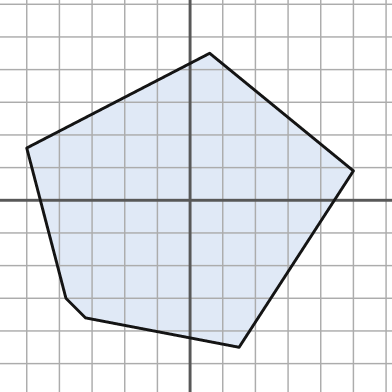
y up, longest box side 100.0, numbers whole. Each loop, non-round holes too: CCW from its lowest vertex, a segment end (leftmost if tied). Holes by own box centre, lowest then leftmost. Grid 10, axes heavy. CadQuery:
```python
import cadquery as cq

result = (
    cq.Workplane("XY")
    .moveTo(15.0, -45.0)
    .lineTo(50.0, 9.0)
    .lineTo(6.0, 45.0)
    .lineTo(-50.0, 16.0)
    .lineTo(-38.0, -30.0)
    .lineTo(-32.0, -36.0)
    .close()
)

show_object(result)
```